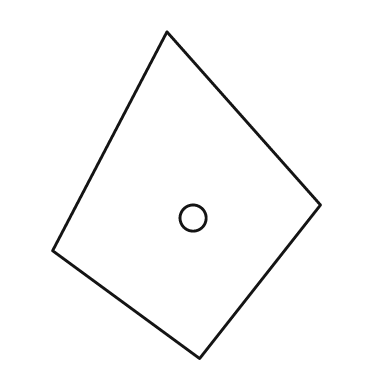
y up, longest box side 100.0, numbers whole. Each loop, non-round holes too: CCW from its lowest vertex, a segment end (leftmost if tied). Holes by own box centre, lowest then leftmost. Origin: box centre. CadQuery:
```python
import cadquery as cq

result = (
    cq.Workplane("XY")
    .moveTo(4.0, -50.0)
    .lineTo(41.0, -3.0)
    .lineTo(-6.0, 50.0)
    .lineTo(-41.0, -17.0)
    .close()
    .moveTo(2.0, -7.0)
    .circle(4.0)
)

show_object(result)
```